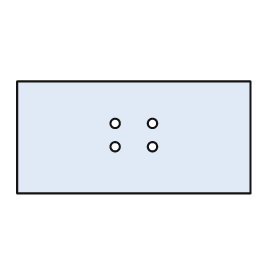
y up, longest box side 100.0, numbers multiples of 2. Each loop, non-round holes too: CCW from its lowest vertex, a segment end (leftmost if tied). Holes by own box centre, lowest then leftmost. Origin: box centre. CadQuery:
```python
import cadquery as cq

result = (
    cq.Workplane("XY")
    .moveTo(-50.0, -24.0)
    .lineTo(50.0, -24.0)
    .lineTo(50.0, 24.0)
    .lineTo(-50.0, 24.0)
    .close()
    .moveTo(-8.0, -4.0)
    .circle(2.0)
    .moveTo(8.0, -4.0)
    .circle(2.0)
    .moveTo(-8.0, 6.0)
    .circle(2.0)
    .moveTo(8.0, 6.0)
    .circle(2.0)
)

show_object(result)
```